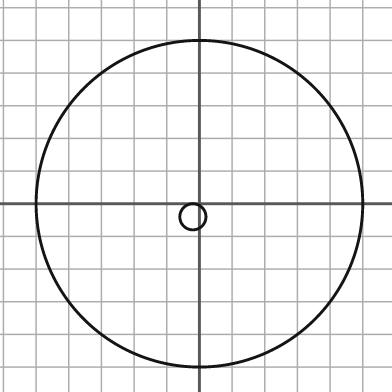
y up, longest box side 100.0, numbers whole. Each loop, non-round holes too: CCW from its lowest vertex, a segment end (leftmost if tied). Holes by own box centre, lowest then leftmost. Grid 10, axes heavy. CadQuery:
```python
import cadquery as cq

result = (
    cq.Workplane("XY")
    .moveTo(0.0, 0.0)
    .circle(50.0)
    .moveTo(-2.0, -4.0)
    .circle(4.0)
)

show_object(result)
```